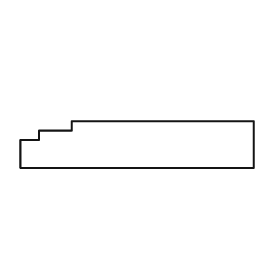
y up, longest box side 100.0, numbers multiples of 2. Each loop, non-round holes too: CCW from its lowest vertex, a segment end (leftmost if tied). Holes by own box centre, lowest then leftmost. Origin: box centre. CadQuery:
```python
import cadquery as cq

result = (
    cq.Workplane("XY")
    .moveTo(-50.0, -10.0)
    .lineTo(50.0, -10.0)
    .lineTo(50.0, 10.0)
    .lineTo(-28.0, 10.0)
    .lineTo(-28.0, 6.0)
    .lineTo(-42.0, 6.0)
    .lineTo(-42.0, 2.0)
    .lineTo(-50.0, 2.0)
    .close()
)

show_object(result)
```